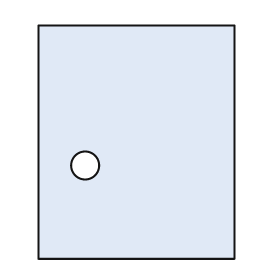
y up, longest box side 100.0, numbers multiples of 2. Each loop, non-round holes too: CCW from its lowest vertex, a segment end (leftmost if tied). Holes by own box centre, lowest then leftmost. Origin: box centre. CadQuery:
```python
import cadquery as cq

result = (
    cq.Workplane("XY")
    .moveTo(-42.0, -50.0)
    .lineTo(42.0, -50.0)
    .lineTo(42.0, 50.0)
    .lineTo(-42.0, 50.0)
    .close()
    .moveTo(-22.0, -10.0)
    .circle(6.0)
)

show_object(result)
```